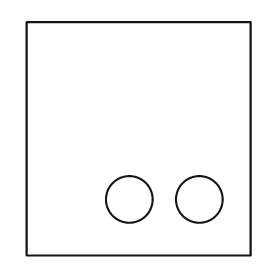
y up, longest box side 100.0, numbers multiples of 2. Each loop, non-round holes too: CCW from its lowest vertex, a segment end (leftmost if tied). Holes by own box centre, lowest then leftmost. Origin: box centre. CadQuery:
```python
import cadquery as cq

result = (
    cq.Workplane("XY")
    .moveTo(-48.0, -50.0)
    .lineTo(48.0, -50.0)
    .lineTo(48.0, 50.0)
    .lineTo(-48.0, 50.0)
    .close()
    .moveTo(-4.0, -26.0)
    .circle(10.0)
    .moveTo(26.0, -26.0)
    .circle(10.0)
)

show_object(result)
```